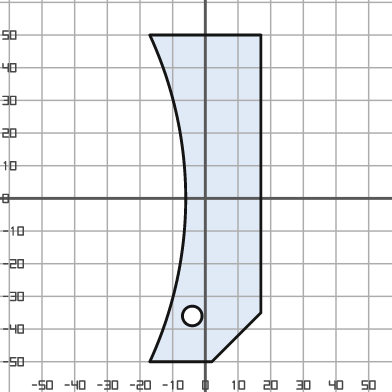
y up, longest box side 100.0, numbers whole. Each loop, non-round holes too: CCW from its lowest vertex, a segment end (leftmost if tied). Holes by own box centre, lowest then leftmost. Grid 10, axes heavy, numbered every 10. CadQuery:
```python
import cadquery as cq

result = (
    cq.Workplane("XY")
    .moveTo(-17.0, -50.0)
    .lineTo(2.0, -50.0)
    .lineTo(17.0, -35.0)
    .lineTo(17.0, 50.0)
    .lineTo(-17.0, 50.0)
    .threePointArc((-6.0, 0.0), (-17.0, -50.0))
    .close()
    .moveTo(-4.0, -36.0)
    .circle(3.0)
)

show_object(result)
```